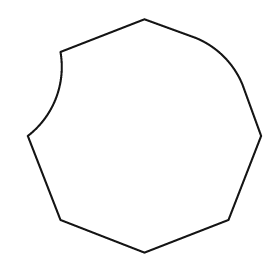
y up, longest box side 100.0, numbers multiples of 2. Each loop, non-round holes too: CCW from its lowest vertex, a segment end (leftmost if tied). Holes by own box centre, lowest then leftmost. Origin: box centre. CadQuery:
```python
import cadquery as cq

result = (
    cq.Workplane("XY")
    .moveTo(0.0, -50.0)
    .lineTo(36.0, -36.0)
    .lineTo(50.0, 0.0)
    .lineTo(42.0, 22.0)
    .threePointArc((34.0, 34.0), (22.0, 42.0))
    .lineTo(0.0, 50.0)
    .lineTo(-36.0, 36.0)
    .threePointArc((-38.0, 16.0), (-50.0, 0.0))
    .lineTo(-36.0, -36.0)
    .close()
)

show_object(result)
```